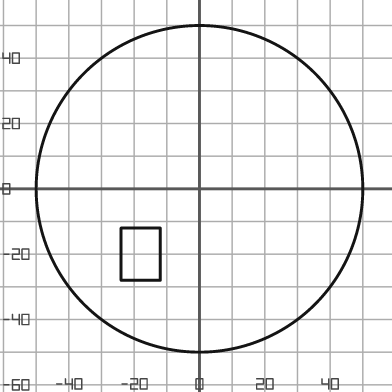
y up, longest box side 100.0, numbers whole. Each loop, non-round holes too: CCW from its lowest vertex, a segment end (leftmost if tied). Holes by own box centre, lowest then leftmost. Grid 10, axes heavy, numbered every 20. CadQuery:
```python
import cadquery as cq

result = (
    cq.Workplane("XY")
    .moveTo(0.0, 0.0)
    .circle(50.0)
    .moveTo(-24.0, -28.0)
    .lineTo(-12.0, -28.0)
    .lineTo(-12.0, -12.0)
    .lineTo(-24.0, -12.0)
    .close()
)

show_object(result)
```